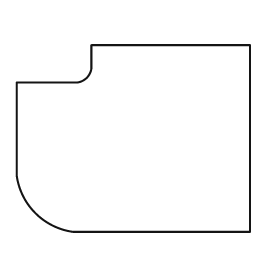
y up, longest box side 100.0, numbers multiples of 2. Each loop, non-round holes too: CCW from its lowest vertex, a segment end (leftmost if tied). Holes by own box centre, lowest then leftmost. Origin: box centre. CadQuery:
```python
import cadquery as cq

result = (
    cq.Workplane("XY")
    .moveTo(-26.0, -40.0)
    .lineTo(50.0, -40.0)
    .lineTo(50.0, 40.0)
    .lineTo(-18.0, 40.0)
    .lineTo(-18.0, 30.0)
    .threePointArc((-20.0, 26.0), (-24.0, 24.0))
    .lineTo(-50.0, 24.0)
    .lineTo(-50.0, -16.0)
    .threePointArc((-42.0, -32.0), (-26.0, -40.0))
    .close()
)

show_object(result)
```